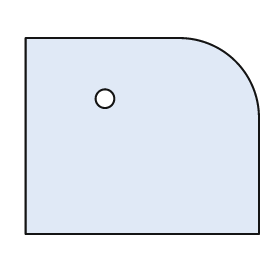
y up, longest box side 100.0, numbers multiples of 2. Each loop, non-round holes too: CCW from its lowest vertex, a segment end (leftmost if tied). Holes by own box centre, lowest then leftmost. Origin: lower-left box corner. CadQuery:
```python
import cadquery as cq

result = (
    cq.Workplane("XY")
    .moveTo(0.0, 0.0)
    .lineTo(100.0, 0.0)
    .lineTo(100.0, 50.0)
    .threePointArc((90.0, 74.0), (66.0, 84.0))
    .lineTo(0.0, 84.0)
    .close()
    .moveTo(34.0, 58.0)
    .circle(4.0)
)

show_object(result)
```